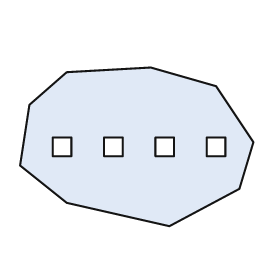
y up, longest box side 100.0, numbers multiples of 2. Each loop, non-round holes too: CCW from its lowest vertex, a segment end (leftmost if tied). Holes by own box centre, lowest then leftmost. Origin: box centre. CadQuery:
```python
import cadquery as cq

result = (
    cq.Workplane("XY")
    .moveTo(14.0, -34.0)
    .lineTo(44.0, -18.0)
    .lineTo(50.0, 2.0)
    .lineTo(34.0, 26.0)
    .lineTo(6.0, 34.0)
    .lineTo(-30.0, 32.0)
    .lineTo(-46.0, 18.0)
    .lineTo(-50.0, -8.0)
    .lineTo(-30.0, -24.0)
    .close()
    .moveTo(-36.0, -4.0)
    .lineTo(-28.0, -4.0)
    .lineTo(-28.0, 4.0)
    .lineTo(-36.0, 4.0)
    .close()
    .moveTo(-14.0, -4.0)
    .lineTo(-6.0, -4.0)
    .lineTo(-6.0, 4.0)
    .lineTo(-14.0, 4.0)
    .close()
    .moveTo(8.0, -4.0)
    .lineTo(16.0, -4.0)
    .lineTo(16.0, 4.0)
    .lineTo(8.0, 4.0)
    .close()
    .moveTo(30.0, -4.0)
    .lineTo(38.0, -4.0)
    .lineTo(38.0, 4.0)
    .lineTo(30.0, 4.0)
    .close()
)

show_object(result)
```